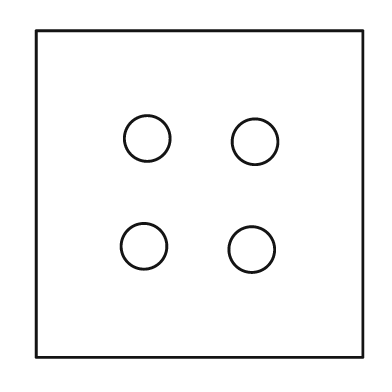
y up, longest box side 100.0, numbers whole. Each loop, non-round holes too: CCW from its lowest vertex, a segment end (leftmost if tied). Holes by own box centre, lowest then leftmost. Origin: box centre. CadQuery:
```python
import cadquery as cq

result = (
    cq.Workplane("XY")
    .moveTo(-50.0, -50.0)
    .lineTo(50.0, -50.0)
    .lineTo(50.0, 50.0)
    .lineTo(-50.0, 50.0)
    .close()
    .moveTo(16.0, -17.0)
    .circle(7.0)
    .moveTo(-17.0, -16.0)
    .circle(7.0)
    .moveTo(17.0, 16.0)
    .circle(7.0)
    .moveTo(-16.0, 17.0)
    .circle(7.0)
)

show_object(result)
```